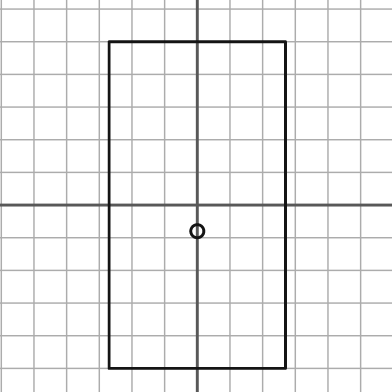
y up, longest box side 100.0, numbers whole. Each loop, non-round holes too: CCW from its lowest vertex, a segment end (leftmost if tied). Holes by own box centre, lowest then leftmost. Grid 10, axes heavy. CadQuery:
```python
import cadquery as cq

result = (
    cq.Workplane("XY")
    .moveTo(-27.0, -50.0)
    .lineTo(27.0, -50.0)
    .lineTo(27.0, 50.0)
    .lineTo(-27.0, 50.0)
    .close()
    .moveTo(0.0, -8.0)
    .circle(2.0)
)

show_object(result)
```